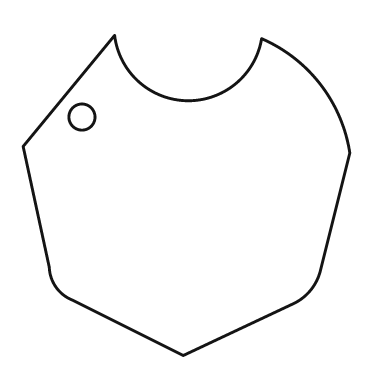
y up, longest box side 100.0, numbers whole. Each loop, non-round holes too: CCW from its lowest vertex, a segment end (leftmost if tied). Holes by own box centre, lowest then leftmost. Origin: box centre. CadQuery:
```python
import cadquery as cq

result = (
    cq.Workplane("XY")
    .moveTo(-1.0, -49.0)
    .lineTo(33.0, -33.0)
    .threePointArc((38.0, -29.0), (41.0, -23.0))
    .lineTo(50.0, 13.0)
    .threePointArc((41.0, 34.0), (23.0, 48.0))
    .threePointArc((0.0, 29.0), (-22.0, 49.0))
    .lineTo(-50.0, 15.0)
    .lineTo(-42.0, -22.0)
    .threePointArc((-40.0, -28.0), (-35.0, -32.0))
    .close()
    .moveTo(-32.0, 24.0)
    .circle(4.0)
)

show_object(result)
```